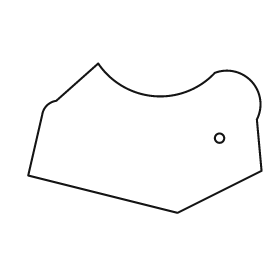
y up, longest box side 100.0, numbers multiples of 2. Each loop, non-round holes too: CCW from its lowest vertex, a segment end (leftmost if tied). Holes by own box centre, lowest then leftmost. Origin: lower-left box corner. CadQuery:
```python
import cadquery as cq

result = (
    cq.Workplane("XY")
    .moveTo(64.0, 0.0)
    .lineTo(100.0, 18.0)
    .lineTo(98.0, 40.0)
    .threePointArc((96.0, 56.0), (80.0, 60.0))
    .threePointArc((54.0, 50.0), (30.0, 64.0))
    .lineTo(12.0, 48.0)
    .threePointArc((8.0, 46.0), (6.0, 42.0))
    .lineTo(0.0, 16.0)
    .close()
    .moveTo(82.0, 32.0)
    .circle(2.0)
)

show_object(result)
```